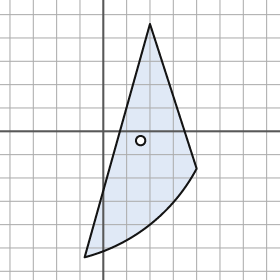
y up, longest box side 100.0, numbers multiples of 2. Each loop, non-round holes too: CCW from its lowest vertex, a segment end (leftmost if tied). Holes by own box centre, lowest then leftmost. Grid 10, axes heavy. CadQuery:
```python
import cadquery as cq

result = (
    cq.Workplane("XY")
    .moveTo(-8.0, -54.0)
    .threePointArc((20.0, -40.0), (40.0, -16.0))
    .lineTo(20.0, 46.0)
    .close()
    .moveTo(16.0, -4.0)
    .circle(2.0)
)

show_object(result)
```